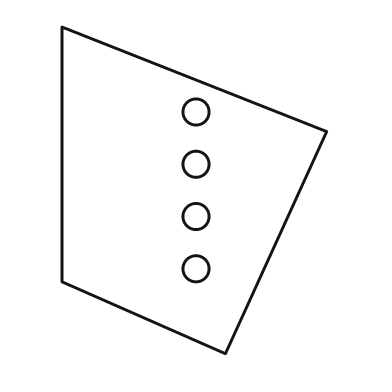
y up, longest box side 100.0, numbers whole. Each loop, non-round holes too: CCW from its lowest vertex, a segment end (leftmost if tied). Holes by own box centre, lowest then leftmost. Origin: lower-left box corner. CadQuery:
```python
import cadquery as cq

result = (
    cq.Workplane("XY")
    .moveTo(50.0, 0.0)
    .lineTo(81.0, 68.0)
    .lineTo(0.0, 100.0)
    .lineTo(0.0, 22.0)
    .close()
    .moveTo(41.0, 26.0)
    .circle(4.0)
    .moveTo(41.0, 42.0)
    .circle(4.0)
    .moveTo(41.0, 58.0)
    .circle(4.0)
    .moveTo(41.0, 74.0)
    .circle(4.0)
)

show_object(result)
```